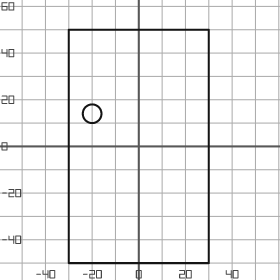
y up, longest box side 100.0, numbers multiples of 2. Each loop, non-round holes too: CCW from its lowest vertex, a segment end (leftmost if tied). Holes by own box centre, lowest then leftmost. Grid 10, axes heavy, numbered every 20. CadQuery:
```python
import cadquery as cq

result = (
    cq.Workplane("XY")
    .moveTo(-30.0, -50.0)
    .lineTo(30.0, -50.0)
    .lineTo(30.0, 50.0)
    .lineTo(-30.0, 50.0)
    .close()
    .moveTo(-20.0, 14.0)
    .circle(4.0)
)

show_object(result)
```